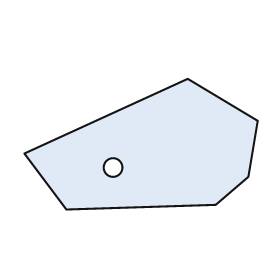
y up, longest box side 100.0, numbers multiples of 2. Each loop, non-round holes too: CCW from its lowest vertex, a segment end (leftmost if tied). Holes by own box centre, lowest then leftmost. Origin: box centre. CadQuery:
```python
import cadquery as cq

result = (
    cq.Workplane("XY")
    .moveTo(-32.0, -28.0)
    .lineTo(32.0, -26.0)
    .lineTo(46.0, -14.0)
    .lineTo(50.0, 10.0)
    .lineTo(20.0, 28.0)
    .lineTo(-50.0, -4.0)
    .close()
    .moveTo(-12.0, -10.0)
    .circle(4.0)
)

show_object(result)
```